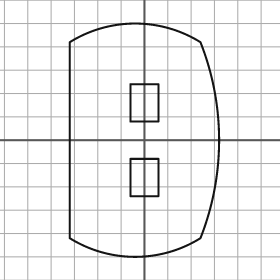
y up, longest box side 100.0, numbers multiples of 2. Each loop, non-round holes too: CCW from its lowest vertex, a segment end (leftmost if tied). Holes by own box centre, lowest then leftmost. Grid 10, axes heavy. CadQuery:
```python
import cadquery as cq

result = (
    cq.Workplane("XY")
    .moveTo(-32.0, -42.0)
    .threePointArc((-4.0, -50.0), (24.0, -42.0))
    .threePointArc((32.0, 0.0), (24.0, 42.0))
    .threePointArc((-4.0, 50.0), (-32.0, 42.0))
    .close()
    .moveTo(-6.0, -24.0)
    .lineTo(6.0, -24.0)
    .lineTo(6.0, -8.0)
    .lineTo(-6.0, -8.0)
    .close()
    .moveTo(-6.0, 8.0)
    .lineTo(6.0, 8.0)
    .lineTo(6.0, 24.0)
    .lineTo(-6.0, 24.0)
    .close()
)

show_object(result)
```